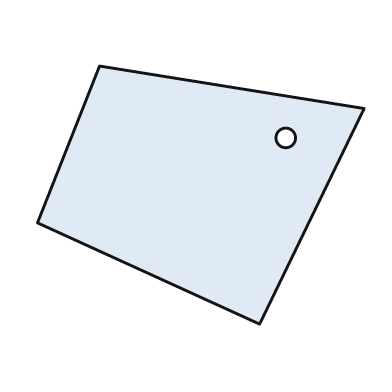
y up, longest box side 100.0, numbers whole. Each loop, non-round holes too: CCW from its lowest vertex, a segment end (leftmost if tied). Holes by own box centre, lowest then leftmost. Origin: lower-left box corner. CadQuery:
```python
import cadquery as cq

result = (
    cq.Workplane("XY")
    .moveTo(68.0, 0.0)
    .lineTo(100.0, 66.0)
    .lineTo(19.0, 79.0)
    .lineTo(0.0, 31.0)
    .close()
    .moveTo(76.0, 57.0)
    .circle(3.0)
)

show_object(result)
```